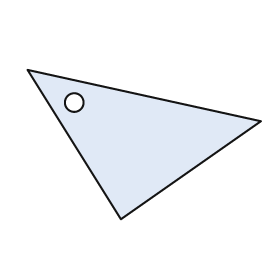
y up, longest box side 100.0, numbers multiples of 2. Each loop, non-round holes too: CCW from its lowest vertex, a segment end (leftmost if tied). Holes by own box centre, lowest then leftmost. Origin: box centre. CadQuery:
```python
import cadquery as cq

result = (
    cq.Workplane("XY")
    .moveTo(-10.0, -32.0)
    .lineTo(50.0, 10.0)
    .lineTo(-50.0, 32.0)
    .close()
    .moveTo(-30.0, 18.0)
    .circle(4.0)
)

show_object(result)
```